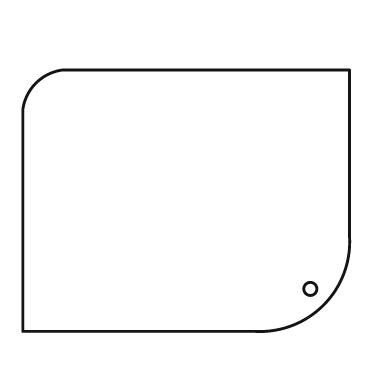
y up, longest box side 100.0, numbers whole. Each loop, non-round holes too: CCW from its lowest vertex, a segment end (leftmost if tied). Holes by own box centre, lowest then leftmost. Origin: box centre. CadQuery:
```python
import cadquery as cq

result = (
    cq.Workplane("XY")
    .moveTo(-50.0, -40.0)
    .lineTo(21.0, -40.0)
    .threePointArc((42.0, -32.0), (50.0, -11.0))
    .lineTo(50.0, 40.0)
    .lineTo(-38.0, 40.0)
    .threePointArc((-46.0, 36.0), (-50.0, 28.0))
    .close()
    .moveTo(38.0, -27.0)
    .circle(2.0)
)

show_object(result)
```